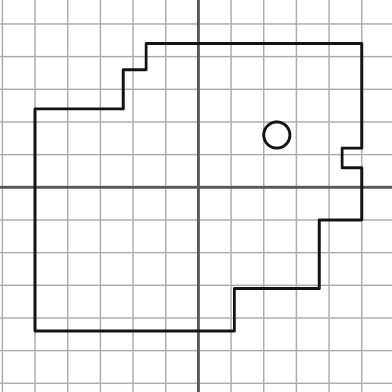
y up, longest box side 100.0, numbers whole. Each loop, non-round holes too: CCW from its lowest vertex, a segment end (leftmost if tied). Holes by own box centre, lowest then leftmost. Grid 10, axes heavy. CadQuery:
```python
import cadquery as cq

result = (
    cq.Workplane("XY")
    .moveTo(-50.0, -44.0)
    .lineTo(11.0, -44.0)
    .lineTo(11.0, -31.0)
    .lineTo(37.0, -31.0)
    .lineTo(37.0, -10.0)
    .lineTo(50.0, -10.0)
    .lineTo(50.0, 6.0)
    .lineTo(44.0, 6.0)
    .lineTo(44.0, 12.0)
    .lineTo(50.0, 12.0)
    .lineTo(50.0, 44.0)
    .lineTo(-16.0, 44.0)
    .lineTo(-16.0, 36.0)
    .lineTo(-23.0, 36.0)
    .lineTo(-23.0, 24.0)
    .lineTo(-50.0, 24.0)
    .close()
    .moveTo(24.0, 16.0)
    .circle(4.0)
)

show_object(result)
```